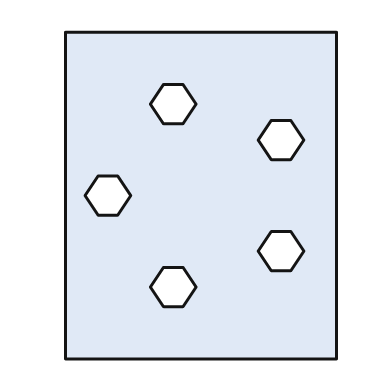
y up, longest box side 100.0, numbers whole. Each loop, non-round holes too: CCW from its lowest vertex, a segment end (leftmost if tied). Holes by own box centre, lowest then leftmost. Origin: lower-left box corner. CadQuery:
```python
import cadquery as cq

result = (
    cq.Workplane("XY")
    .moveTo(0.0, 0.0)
    .lineTo(83.0, 0.0)
    .lineTo(83.0, 100.0)
    .lineTo(0.0, 100.0)
    .close()
    .moveTo(30.0, 16.0)
    .lineTo(36.0, 16.0)
    .lineTo(40.0, 22.0)
    .lineTo(36.0, 28.0)
    .lineTo(30.0, 28.0)
    .lineTo(26.0, 22.0)
    .close()
    .moveTo(63.0, 27.0)
    .lineTo(69.0, 27.0)
    .lineTo(73.0, 33.0)
    .lineTo(69.0, 39.0)
    .lineTo(63.0, 39.0)
    .lineTo(59.0, 33.0)
    .close()
    .moveTo(10.0, 44.0)
    .lineTo(16.0, 44.0)
    .lineTo(20.0, 50.0)
    .lineTo(16.0, 56.0)
    .lineTo(10.0, 56.0)
    .lineTo(6.0, 50.0)
    .close()
    .moveTo(63.0, 61.0)
    .lineTo(69.0, 61.0)
    .lineTo(73.0, 67.0)
    .lineTo(69.0, 73.0)
    .lineTo(63.0, 73.0)
    .lineTo(59.0, 67.0)
    .close()
    .moveTo(30.0, 72.0)
    .lineTo(36.0, 72.0)
    .lineTo(40.0, 78.0)
    .lineTo(36.0, 84.0)
    .lineTo(30.0, 84.0)
    .lineTo(26.0, 78.0)
    .close()
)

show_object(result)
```